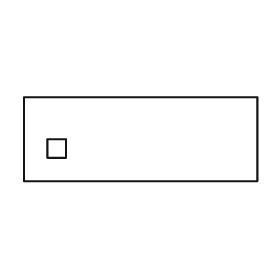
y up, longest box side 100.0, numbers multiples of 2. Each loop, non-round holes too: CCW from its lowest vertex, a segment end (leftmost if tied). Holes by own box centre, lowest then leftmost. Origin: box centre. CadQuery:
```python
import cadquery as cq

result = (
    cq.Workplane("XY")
    .moveTo(-50.0, -18.0)
    .lineTo(50.0, -18.0)
    .lineTo(50.0, 18.0)
    .lineTo(-50.0, 18.0)
    .close()
    .moveTo(-40.0, -8.0)
    .lineTo(-32.0, -8.0)
    .lineTo(-32.0, 0.0)
    .lineTo(-40.0, 0.0)
    .close()
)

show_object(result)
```